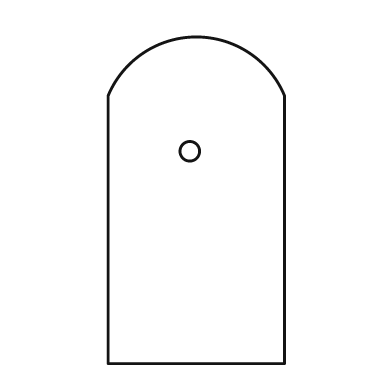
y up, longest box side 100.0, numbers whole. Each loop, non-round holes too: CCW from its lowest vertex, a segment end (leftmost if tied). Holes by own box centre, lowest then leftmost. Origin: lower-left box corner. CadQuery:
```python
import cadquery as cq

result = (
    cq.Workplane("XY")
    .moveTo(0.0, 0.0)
    .lineTo(54.0, 0.0)
    .lineTo(54.0, 82.0)
    .threePointArc((27.0, 100.0), (0.0, 82.0))
    .close()
    .moveTo(25.0, 65.0)
    .circle(3.0)
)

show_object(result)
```